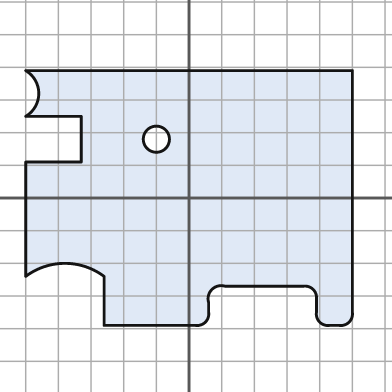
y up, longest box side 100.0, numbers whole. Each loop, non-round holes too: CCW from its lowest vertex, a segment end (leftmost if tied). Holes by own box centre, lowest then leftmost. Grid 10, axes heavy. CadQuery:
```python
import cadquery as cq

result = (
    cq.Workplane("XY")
    .moveTo(-26.0, -39.0)
    .lineTo(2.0, -39.0)
    .threePointArc((5.0, -38.0), (6.0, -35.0))
    .lineTo(6.0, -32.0)
    .threePointArc((7.0, -28.0), (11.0, -27.0))
    .lineTo(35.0, -27.0)
    .threePointArc((38.0, -28.0), (39.0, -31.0))
    .lineTo(39.0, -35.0)
    .threePointArc((40.0, -38.0), (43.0, -39.0))
    .lineTo(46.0, -39.0)
    .threePointArc((49.0, -38.0), (50.0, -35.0))
    .lineTo(50.0, 39.0)
    .lineTo(-50.0, 39.0)
    .threePointArc((-46.0, 32.0), (-50.0, 25.0))
    .lineTo(-33.0, 25.0)
    .lineTo(-33.0, 11.0)
    .lineTo(-50.0, 11.0)
    .lineTo(-50.0, -24.0)
    .threePointArc((-38.0, -20.0), (-26.0, -24.0))
    .close()
    .moveTo(-10.0, 18.0)
    .circle(4.0)
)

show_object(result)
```